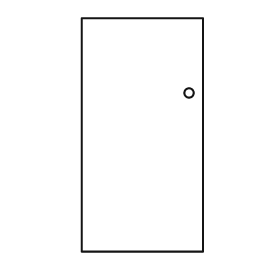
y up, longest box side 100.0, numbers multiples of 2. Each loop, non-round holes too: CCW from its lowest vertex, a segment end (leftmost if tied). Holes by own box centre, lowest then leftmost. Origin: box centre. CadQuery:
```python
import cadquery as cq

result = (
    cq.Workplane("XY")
    .moveTo(-26.0, -50.0)
    .lineTo(26.0, -50.0)
    .lineTo(26.0, 50.0)
    .lineTo(-26.0, 50.0)
    .close()
    .moveTo(20.0, 18.0)
    .circle(2.0)
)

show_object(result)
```